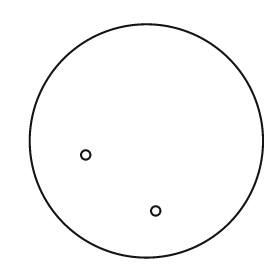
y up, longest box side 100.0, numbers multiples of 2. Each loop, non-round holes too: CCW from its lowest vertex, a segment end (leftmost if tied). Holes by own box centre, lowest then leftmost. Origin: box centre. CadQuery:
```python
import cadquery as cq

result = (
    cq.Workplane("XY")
    .moveTo(0.0, 0.0)
    .circle(50.0)
    .moveTo(4.0, -30.0)
    .circle(2.0)
    .moveTo(-26.0, -6.0)
    .circle(2.0)
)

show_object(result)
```